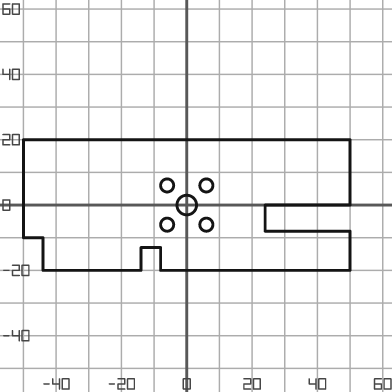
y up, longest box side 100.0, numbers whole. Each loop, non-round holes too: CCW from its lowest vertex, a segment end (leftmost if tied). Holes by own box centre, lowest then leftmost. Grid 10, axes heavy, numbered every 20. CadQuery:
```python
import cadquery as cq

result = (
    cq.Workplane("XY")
    .moveTo(-44.0, -20.0)
    .lineTo(-14.0, -20.0)
    .lineTo(-14.0, -13.0)
    .lineTo(-8.0, -13.0)
    .lineTo(-8.0, -20.0)
    .lineTo(50.0, -20.0)
    .lineTo(50.0, -8.0)
    .lineTo(24.0, -8.0)
    .lineTo(24.0, 0.0)
    .lineTo(50.0, 0.0)
    .lineTo(50.0, 20.0)
    .lineTo(-50.0, 20.0)
    .lineTo(-50.0, -10.0)
    .lineTo(-44.0, -10.0)
    .close()
    .moveTo(-6.0, -6.0)
    .circle(2.0)
    .moveTo(6.0, -6.0)
    .circle(2.0)
    .moveTo(0.0, 0.0)
    .circle(3.0)
    .moveTo(-6.0, 6.0)
    .circle(2.0)
    .moveTo(6.0, 6.0)
    .circle(2.0)
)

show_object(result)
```